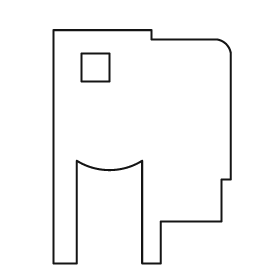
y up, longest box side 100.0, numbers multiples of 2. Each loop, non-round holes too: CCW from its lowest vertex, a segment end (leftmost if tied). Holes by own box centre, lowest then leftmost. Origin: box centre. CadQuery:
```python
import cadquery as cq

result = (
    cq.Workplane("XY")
    .moveTo(-38.0, -50.0)
    .lineTo(-28.0, -50.0)
    .lineTo(-28.0, -6.0)
    .threePointArc((-14.0, -10.0), (0.0, -6.0))
    .lineTo(0.0, -50.0)
    .lineTo(8.0, -50.0)
    .lineTo(8.0, -32.0)
    .lineTo(34.0, -32.0)
    .lineTo(34.0, -14.0)
    .lineTo(38.0, -14.0)
    .lineTo(38.0, 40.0)
    .threePointArc((36.0, 44.0), (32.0, 46.0))
    .lineTo(4.0, 46.0)
    .lineTo(4.0, 50.0)
    .lineTo(-38.0, 50.0)
    .close()
    .moveTo(-26.0, 28.0)
    .lineTo(-14.0, 28.0)
    .lineTo(-14.0, 40.0)
    .lineTo(-26.0, 40.0)
    .close()
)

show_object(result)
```